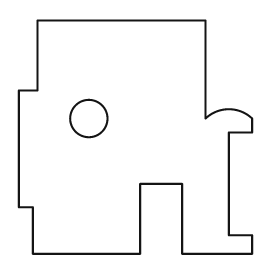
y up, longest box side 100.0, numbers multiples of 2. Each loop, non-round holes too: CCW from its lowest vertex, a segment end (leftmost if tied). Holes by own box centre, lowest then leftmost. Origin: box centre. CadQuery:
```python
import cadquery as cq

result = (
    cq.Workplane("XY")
    .moveTo(-44.0, -50.0)
    .lineTo(2.0, -50.0)
    .lineTo(2.0, -20.0)
    .lineTo(20.0, -20.0)
    .lineTo(20.0, -50.0)
    .lineTo(50.0, -50.0)
    .lineTo(50.0, -42.0)
    .lineTo(40.0, -42.0)
    .lineTo(40.0, 2.0)
    .lineTo(50.0, 2.0)
    .lineTo(50.0, 8.0)
    .threePointArc((40.0, 12.0), (30.0, 8.0))
    .lineTo(30.0, 50.0)
    .lineTo(-42.0, 50.0)
    .lineTo(-42.0, 20.0)
    .lineTo(-50.0, 20.0)
    .lineTo(-50.0, -30.0)
    .lineTo(-44.0, -30.0)
    .close()
    .moveTo(-20.0, 8.0)
    .circle(8.0)
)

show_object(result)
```